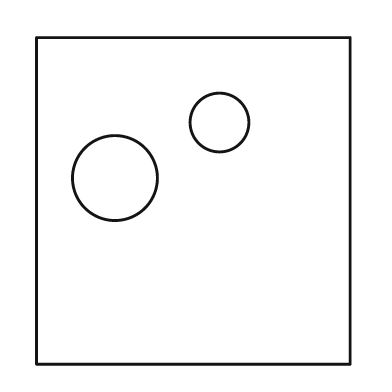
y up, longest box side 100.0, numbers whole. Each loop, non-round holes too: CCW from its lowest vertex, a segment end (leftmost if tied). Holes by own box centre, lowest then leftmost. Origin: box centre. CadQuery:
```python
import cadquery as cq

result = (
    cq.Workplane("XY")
    .moveTo(-48.0, -50.0)
    .lineTo(48.0, -50.0)
    .lineTo(48.0, 50.0)
    .lineTo(-48.0, 50.0)
    .close()
    .moveTo(-24.0, 7.0)
    .circle(13.0)
    .moveTo(8.0, 24.0)
    .circle(9.0)
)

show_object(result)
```